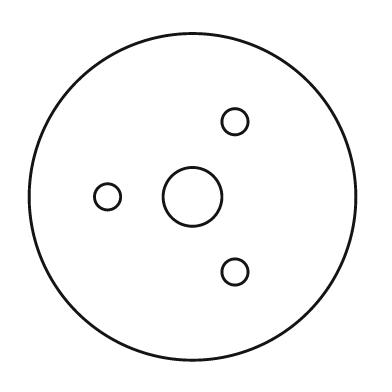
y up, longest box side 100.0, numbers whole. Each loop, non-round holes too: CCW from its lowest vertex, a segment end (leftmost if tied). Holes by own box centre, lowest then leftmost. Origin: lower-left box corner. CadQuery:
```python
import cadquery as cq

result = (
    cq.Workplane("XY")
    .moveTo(50.0, 50.0)
    .circle(50.0)
    .moveTo(63.0, 27.0)
    .circle(4.0)
    .moveTo(24.0, 50.0)
    .circle(4.0)
    .moveTo(50.0, 50.0)
    .circle(9.0)
    .moveTo(63.0, 73.0)
    .circle(4.0)
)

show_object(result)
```